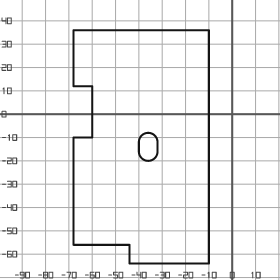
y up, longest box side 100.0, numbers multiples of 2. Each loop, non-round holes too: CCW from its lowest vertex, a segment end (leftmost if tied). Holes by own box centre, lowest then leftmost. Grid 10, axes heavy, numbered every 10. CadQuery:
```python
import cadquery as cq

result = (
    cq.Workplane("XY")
    .moveTo(-44.0, -64.0)
    .lineTo(-10.0, -64.0)
    .lineTo(-10.0, 36.0)
    .lineTo(-68.0, 36.0)
    .lineTo(-68.0, 12.0)
    .lineTo(-60.0, 12.0)
    .lineTo(-60.0, -10.0)
    .lineTo(-68.0, -10.0)
    .lineTo(-68.0, -56.0)
    .lineTo(-44.0, -56.0)
    .close()
    .moveTo(-40.0, -16.0)
    .threePointArc((-36.0, -20.0), (-32.0, -16.0))
    .lineTo(-32.0, -12.0)
    .threePointArc((-36.0, -8.0), (-40.0, -12.0))
    .close()
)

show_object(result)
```